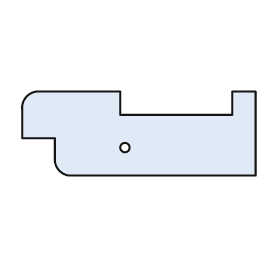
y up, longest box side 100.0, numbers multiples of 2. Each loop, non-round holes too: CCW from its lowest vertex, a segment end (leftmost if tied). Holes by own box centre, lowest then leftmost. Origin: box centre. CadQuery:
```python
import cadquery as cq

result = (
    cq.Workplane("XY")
    .moveTo(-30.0, -18.0)
    .lineTo(50.0, -18.0)
    .lineTo(50.0, 18.0)
    .lineTo(40.0, 18.0)
    .lineTo(40.0, 8.0)
    .lineTo(-8.0, 8.0)
    .lineTo(-8.0, 18.0)
    .lineTo(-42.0, 18.0)
    .threePointArc((-48.0, 16.0), (-50.0, 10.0))
    .lineTo(-50.0, -2.0)
    .lineTo(-36.0, -2.0)
    .lineTo(-36.0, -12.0)
    .threePointArc((-34.0, -16.0), (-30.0, -18.0))
    .close()
    .moveTo(-6.0, -6.0)
    .circle(2.0)
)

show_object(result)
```